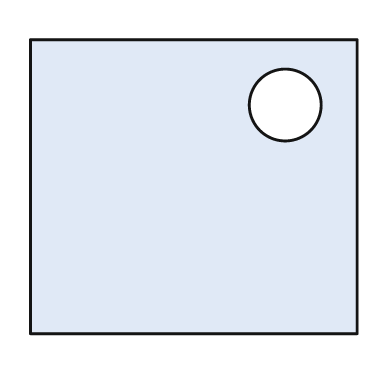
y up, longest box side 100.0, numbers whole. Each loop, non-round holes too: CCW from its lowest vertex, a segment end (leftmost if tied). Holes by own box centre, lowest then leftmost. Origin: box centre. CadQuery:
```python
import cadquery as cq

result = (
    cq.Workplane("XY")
    .moveTo(-50.0, -45.0)
    .lineTo(50.0, -45.0)
    .lineTo(50.0, 45.0)
    .lineTo(-50.0, 45.0)
    .close()
    .moveTo(28.0, 25.0)
    .circle(11.0)
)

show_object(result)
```